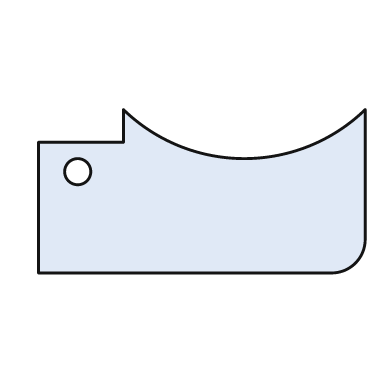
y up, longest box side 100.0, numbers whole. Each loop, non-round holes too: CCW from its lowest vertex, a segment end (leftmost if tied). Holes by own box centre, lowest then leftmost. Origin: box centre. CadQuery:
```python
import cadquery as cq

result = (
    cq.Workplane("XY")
    .moveTo(-50.0, -25.0)
    .lineTo(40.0, -25.0)
    .threePointArc((47.0, -22.0), (50.0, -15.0))
    .lineTo(50.0, 25.0)
    .threePointArc((13.0, 10.0), (-24.0, 25.0))
    .lineTo(-24.0, 15.0)
    .lineTo(-50.0, 15.0)
    .close()
    .moveTo(-38.0, 6.0)
    .circle(4.0)
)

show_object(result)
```